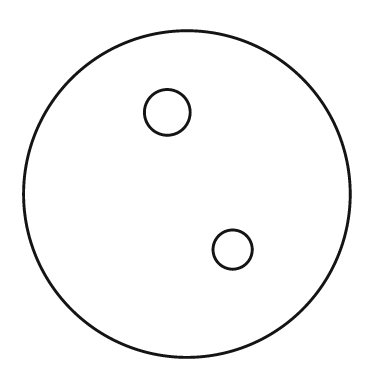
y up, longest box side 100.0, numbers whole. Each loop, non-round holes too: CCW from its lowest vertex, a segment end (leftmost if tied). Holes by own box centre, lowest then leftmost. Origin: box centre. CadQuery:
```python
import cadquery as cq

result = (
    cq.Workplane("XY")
    .moveTo(0.0, 0.0)
    .circle(50.0)
    .moveTo(14.0, -17.0)
    .circle(6.0)
    .moveTo(-6.0, 25.0)
    .circle(7.0)
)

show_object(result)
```